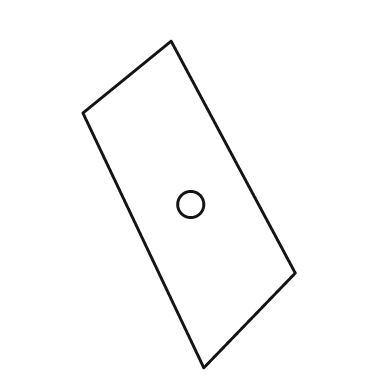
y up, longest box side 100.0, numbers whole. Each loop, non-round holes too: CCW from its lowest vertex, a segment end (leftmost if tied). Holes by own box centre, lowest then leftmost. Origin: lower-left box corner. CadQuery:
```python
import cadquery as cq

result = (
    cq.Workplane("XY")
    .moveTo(37.0, 0.0)
    .lineTo(65.0, 29.0)
    .lineTo(27.0, 100.0)
    .lineTo(0.0, 78.0)
    .close()
    .moveTo(33.0, 50.0)
    .circle(4.0)
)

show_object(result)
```